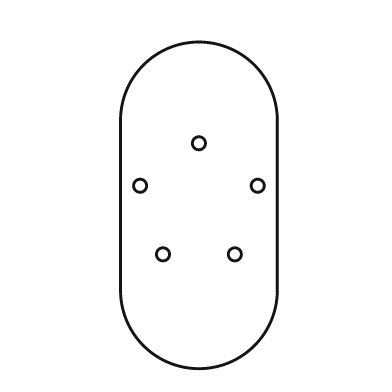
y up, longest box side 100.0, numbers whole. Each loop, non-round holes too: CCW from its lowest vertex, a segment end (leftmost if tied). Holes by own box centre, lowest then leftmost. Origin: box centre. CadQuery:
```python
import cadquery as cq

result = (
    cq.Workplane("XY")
    .moveTo(-24.0, -26.0)
    .threePointArc((0.0, -50.0), (24.0, -26.0))
    .lineTo(24.0, 26.0)
    .threePointArc((0.0, 50.0), (-24.0, 26.0))
    .close()
    .moveTo(-11.0, -15.0)
    .circle(2.0)
    .moveTo(11.0, -15.0)
    .circle(2.0)
    .moveTo(-18.0, 6.0)
    .circle(2.0)
    .moveTo(18.0, 6.0)
    .circle(2.0)
    .moveTo(0.0, 19.0)
    .circle(2.0)
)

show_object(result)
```